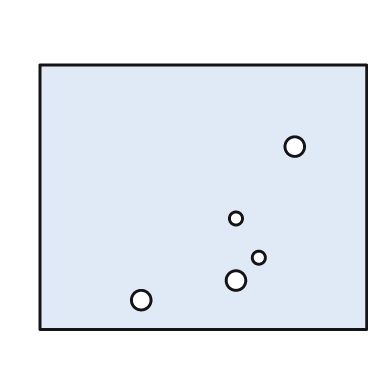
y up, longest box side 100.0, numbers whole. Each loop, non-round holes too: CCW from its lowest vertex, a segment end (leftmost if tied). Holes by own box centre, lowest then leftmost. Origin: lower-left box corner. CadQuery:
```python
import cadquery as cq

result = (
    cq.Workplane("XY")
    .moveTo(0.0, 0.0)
    .lineTo(100.0, 0.0)
    .lineTo(100.0, 81.0)
    .lineTo(0.0, 81.0)
    .close()
    .moveTo(31.0, 9.0)
    .circle(3.0)
    .moveTo(60.0, 15.0)
    .circle(3.0)
    .moveTo(67.0, 22.0)
    .circle(2.0)
    .moveTo(60.0, 34.0)
    .circle(2.0)
    .moveTo(78.0, 56.0)
    .circle(3.0)
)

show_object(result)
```